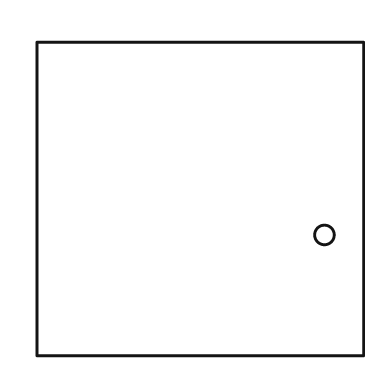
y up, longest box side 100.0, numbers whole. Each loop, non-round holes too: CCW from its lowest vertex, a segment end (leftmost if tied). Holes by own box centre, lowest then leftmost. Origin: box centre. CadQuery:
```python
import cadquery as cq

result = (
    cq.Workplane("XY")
    .moveTo(-50.0, -48.0)
    .lineTo(50.0, -48.0)
    .lineTo(50.0, 48.0)
    .lineTo(-50.0, 48.0)
    .close()
    .moveTo(38.0, -11.0)
    .circle(3.0)
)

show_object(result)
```